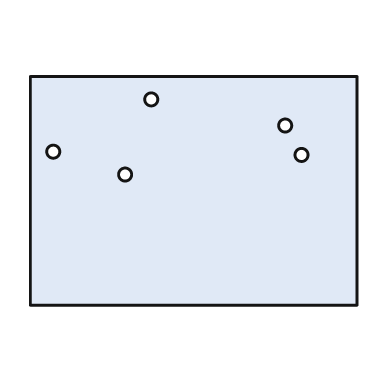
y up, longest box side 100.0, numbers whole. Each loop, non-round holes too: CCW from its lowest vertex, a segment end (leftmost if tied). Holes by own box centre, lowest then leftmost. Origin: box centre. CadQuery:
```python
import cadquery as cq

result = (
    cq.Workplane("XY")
    .moveTo(-50.0, -35.0)
    .lineTo(50.0, -35.0)
    .lineTo(50.0, 35.0)
    .lineTo(-50.0, 35.0)
    .close()
    .moveTo(-21.0, 5.0)
    .circle(2.0)
    .moveTo(33.0, 11.0)
    .circle(2.0)
    .moveTo(-43.0, 12.0)
    .circle(2.0)
    .moveTo(28.0, 20.0)
    .circle(2.0)
    .moveTo(-13.0, 28.0)
    .circle(2.0)
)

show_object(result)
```